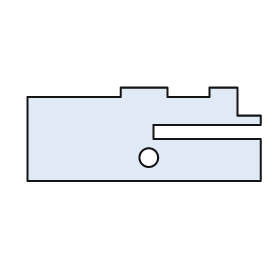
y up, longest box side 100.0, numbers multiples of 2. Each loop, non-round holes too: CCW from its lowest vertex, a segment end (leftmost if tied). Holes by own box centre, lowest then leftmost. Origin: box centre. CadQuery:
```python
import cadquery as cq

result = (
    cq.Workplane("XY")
    .moveTo(-50.0, -20.0)
    .lineTo(50.0, -20.0)
    .lineTo(50.0, -2.0)
    .lineTo(4.0, -2.0)
    .lineTo(4.0, 4.0)
    .lineTo(50.0, 4.0)
    .lineTo(50.0, 8.0)
    .lineTo(40.0, 8.0)
    .lineTo(40.0, 20.0)
    .lineTo(28.0, 20.0)
    .lineTo(28.0, 16.0)
    .lineTo(10.0, 16.0)
    .lineTo(10.0, 20.0)
    .lineTo(-10.0, 20.0)
    .lineTo(-10.0, 16.0)
    .lineTo(-50.0, 16.0)
    .close()
    .moveTo(2.0, -10.0)
    .circle(4.0)
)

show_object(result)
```